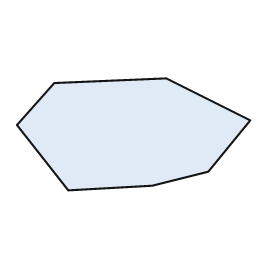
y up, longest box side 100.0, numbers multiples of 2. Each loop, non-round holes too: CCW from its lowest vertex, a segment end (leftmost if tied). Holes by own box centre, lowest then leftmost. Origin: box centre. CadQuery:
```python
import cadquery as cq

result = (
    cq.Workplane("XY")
    .moveTo(-28.0, -24.0)
    .lineTo(8.0, -22.0)
    .lineTo(32.0, -16.0)
    .lineTo(50.0, 6.0)
    .lineTo(14.0, 24.0)
    .lineTo(-34.0, 22.0)
    .lineTo(-50.0, 4.0)
    .close()
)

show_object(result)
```